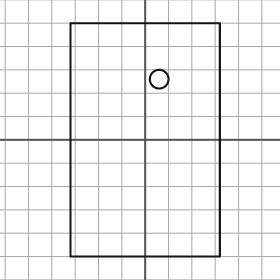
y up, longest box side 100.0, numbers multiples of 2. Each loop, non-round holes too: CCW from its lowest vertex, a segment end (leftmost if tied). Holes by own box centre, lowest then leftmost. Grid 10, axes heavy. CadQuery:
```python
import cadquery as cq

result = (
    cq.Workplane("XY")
    .moveTo(-32.0, -50.0)
    .lineTo(32.0, -50.0)
    .lineTo(32.0, 50.0)
    .lineTo(-32.0, 50.0)
    .close()
    .moveTo(6.0, 26.0)
    .circle(4.0)
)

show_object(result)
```